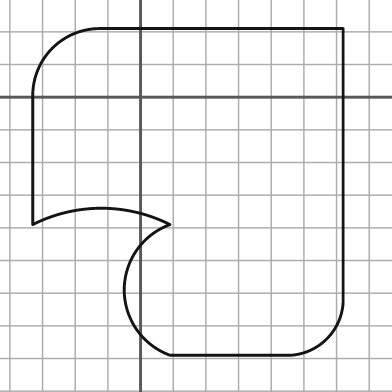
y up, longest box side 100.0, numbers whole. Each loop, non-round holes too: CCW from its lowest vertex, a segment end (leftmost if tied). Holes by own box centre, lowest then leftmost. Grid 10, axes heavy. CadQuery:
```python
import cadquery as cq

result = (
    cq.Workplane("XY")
    .moveTo(9.0, -79.0)
    .lineTo(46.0, -79.0)
    .threePointArc((57.0, -74.0), (62.0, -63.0))
    .lineTo(62.0, 21.0)
    .lineTo(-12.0, 21.0)
    .threePointArc((-27.0, 15.0), (-33.0, 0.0))
    .lineTo(-33.0, -39.0)
    .threePointArc((-12.0, -34.0), (9.0, -39.0))
    .threePointArc((-5.0, -59.0), (9.0, -79.0))
    .close()
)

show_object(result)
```